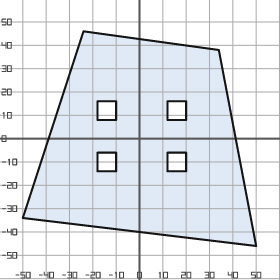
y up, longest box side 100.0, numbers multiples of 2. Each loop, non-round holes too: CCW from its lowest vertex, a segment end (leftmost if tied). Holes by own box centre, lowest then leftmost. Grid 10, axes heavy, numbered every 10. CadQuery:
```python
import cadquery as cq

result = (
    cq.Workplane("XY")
    .moveTo(50.0, -46.0)
    .lineTo(34.0, 38.0)
    .lineTo(-24.0, 46.0)
    .lineTo(-50.0, -34.0)
    .close()
    .moveTo(-18.0, -14.0)
    .lineTo(-10.0, -14.0)
    .lineTo(-10.0, -6.0)
    .lineTo(-18.0, -6.0)
    .close()
    .moveTo(12.0, -14.0)
    .lineTo(20.0, -14.0)
    .lineTo(20.0, -6.0)
    .lineTo(12.0, -6.0)
    .close()
    .moveTo(-18.0, 8.0)
    .lineTo(-10.0, 8.0)
    .lineTo(-10.0, 16.0)
    .lineTo(-18.0, 16.0)
    .close()
    .moveTo(12.0, 8.0)
    .lineTo(20.0, 8.0)
    .lineTo(20.0, 16.0)
    .lineTo(12.0, 16.0)
    .close()
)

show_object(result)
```